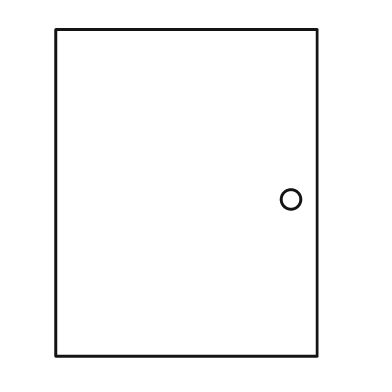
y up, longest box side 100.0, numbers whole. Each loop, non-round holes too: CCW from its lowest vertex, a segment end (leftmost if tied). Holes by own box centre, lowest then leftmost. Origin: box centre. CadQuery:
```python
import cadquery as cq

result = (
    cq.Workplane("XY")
    .moveTo(-40.0, -50.0)
    .lineTo(40.0, -50.0)
    .lineTo(40.0, 50.0)
    .lineTo(-40.0, 50.0)
    .close()
    .moveTo(32.0, -2.0)
    .circle(3.0)
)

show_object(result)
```